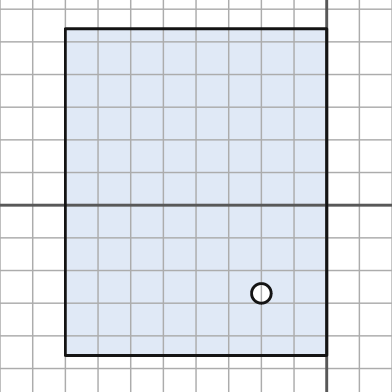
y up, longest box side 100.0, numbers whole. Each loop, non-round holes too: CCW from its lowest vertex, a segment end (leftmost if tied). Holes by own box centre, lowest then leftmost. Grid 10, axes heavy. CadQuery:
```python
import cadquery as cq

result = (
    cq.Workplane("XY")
    .moveTo(-80.0, -46.0)
    .lineTo(0.0, -46.0)
    .lineTo(0.0, 54.0)
    .lineTo(-80.0, 54.0)
    .close()
    .moveTo(-20.0, -27.0)
    .circle(3.0)
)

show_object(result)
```